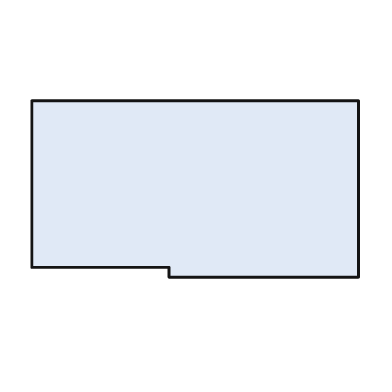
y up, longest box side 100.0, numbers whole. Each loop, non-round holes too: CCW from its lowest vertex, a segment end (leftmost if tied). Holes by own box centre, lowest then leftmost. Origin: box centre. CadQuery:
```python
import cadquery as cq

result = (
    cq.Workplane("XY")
    .moveTo(-8.0, -27.0)
    .lineTo(50.0, -27.0)
    .lineTo(50.0, 27.0)
    .lineTo(-50.0, 27.0)
    .lineTo(-50.0, -24.0)
    .lineTo(-8.0, -24.0)
    .close()
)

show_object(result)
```